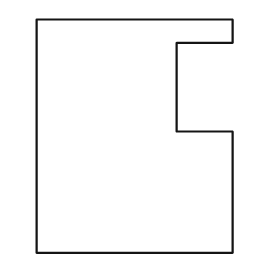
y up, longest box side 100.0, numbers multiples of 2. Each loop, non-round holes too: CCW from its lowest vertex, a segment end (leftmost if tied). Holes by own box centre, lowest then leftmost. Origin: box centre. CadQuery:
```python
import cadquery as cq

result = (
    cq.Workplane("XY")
    .moveTo(-42.0, -50.0)
    .lineTo(42.0, -50.0)
    .lineTo(42.0, 2.0)
    .lineTo(18.0, 2.0)
    .lineTo(18.0, 40.0)
    .lineTo(42.0, 40.0)
    .lineTo(42.0, 50.0)
    .lineTo(-42.0, 50.0)
    .close()
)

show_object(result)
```